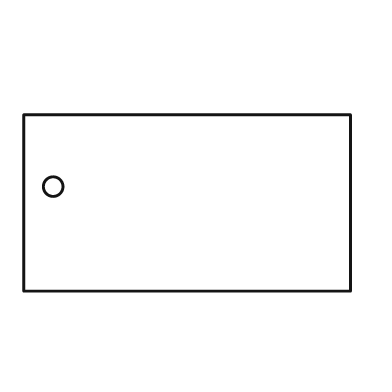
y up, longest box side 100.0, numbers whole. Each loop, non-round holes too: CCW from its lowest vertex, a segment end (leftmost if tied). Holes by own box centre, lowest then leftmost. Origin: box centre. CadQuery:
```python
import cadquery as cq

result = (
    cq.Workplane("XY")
    .moveTo(-50.0, -27.0)
    .lineTo(50.0, -27.0)
    .lineTo(50.0, 27.0)
    .lineTo(-50.0, 27.0)
    .close()
    .moveTo(-41.0, 5.0)
    .circle(3.0)
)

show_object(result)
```